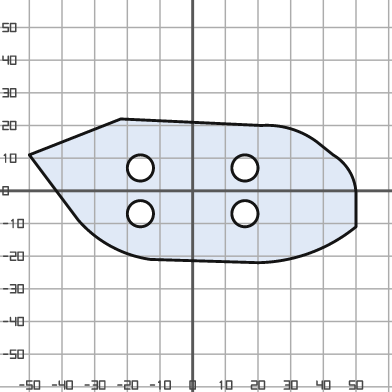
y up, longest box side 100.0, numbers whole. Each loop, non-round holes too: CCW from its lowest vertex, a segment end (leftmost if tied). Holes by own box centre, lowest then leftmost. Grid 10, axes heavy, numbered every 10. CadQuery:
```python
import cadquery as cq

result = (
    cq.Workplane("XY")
    .moveTo(20.0, -22.0)
    .threePointArc((36.0, -19.0), (50.0, -11.0))
    .lineTo(50.0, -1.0)
    .threePointArc((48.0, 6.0), (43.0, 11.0))
    .lineTo(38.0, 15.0)
    .threePointArc((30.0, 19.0), (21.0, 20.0))
    .lineTo(-22.0, 22.0)
    .lineTo(-50.0, 11.0)
    .lineTo(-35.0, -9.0)
    .threePointArc((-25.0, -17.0), (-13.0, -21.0))
    .close()
    .moveTo(-16.0, -7.0)
    .circle(4.0)
    .moveTo(16.0, -7.0)
    .circle(4.0)
    .moveTo(-16.0, 7.0)
    .circle(4.0)
    .moveTo(16.0, 7.0)
    .circle(4.0)
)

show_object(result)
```